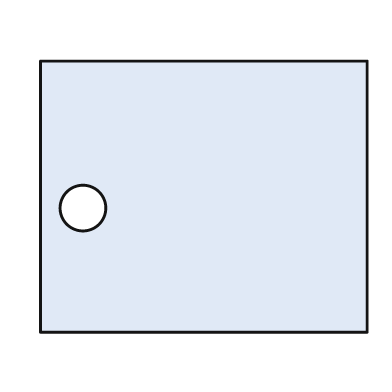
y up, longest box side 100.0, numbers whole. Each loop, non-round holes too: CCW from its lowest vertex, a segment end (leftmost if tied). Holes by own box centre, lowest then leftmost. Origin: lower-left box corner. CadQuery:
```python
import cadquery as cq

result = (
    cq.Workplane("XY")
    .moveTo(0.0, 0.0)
    .lineTo(100.0, 0.0)
    .lineTo(100.0, 83.0)
    .lineTo(0.0, 83.0)
    .close()
    .moveTo(13.0, 38.0)
    .circle(7.0)
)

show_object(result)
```